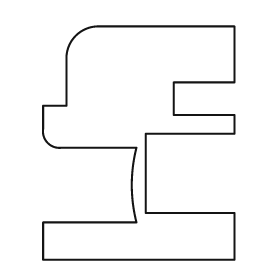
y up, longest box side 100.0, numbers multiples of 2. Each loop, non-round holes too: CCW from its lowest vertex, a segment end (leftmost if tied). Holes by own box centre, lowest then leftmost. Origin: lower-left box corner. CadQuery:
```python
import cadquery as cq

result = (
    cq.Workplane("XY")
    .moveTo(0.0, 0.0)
    .lineTo(82.0, 0.0)
    .lineTo(82.0, 20.0)
    .lineTo(44.0, 20.0)
    .lineTo(44.0, 54.0)
    .lineTo(82.0, 54.0)
    .lineTo(82.0, 62.0)
    .lineTo(56.0, 62.0)
    .lineTo(56.0, 76.0)
    .lineTo(82.0, 76.0)
    .lineTo(82.0, 100.0)
    .lineTo(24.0, 100.0)
    .threePointArc((14.0, 96.0), (10.0, 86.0))
    .lineTo(10.0, 66.0)
    .lineTo(0.0, 66.0)
    .lineTo(0.0, 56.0)
    .threePointArc((2.0, 50.0), (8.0, 48.0))
    .lineTo(40.0, 48.0)
    .threePointArc((38.0, 32.0), (40.0, 16.0))
    .lineTo(0.0, 16.0)
    .close()
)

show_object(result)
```